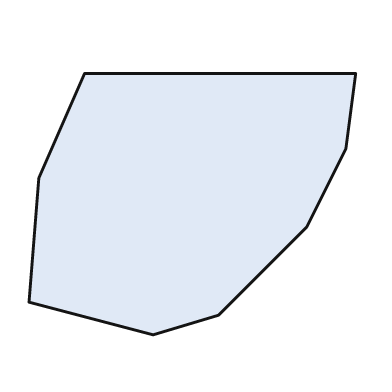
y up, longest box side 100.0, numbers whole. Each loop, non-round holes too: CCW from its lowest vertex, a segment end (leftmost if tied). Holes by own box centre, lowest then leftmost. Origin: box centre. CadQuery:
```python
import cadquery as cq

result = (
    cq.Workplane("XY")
    .moveTo(-12.0, -40.0)
    .lineTo(8.0, -34.0)
    .lineTo(35.0, -7.0)
    .lineTo(47.0, 17.0)
    .lineTo(50.0, 40.0)
    .lineTo(-33.0, 40.0)
    .lineTo(-47.0, 8.0)
    .lineTo(-50.0, -30.0)
    .close()
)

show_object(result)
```